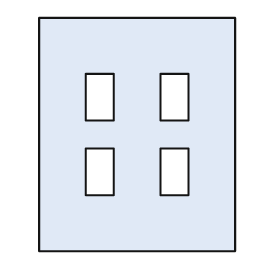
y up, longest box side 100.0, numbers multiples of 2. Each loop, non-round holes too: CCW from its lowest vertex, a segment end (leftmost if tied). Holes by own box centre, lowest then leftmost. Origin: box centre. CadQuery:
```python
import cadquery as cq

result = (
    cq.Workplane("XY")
    .moveTo(-42.0, -50.0)
    .lineTo(42.0, -50.0)
    .lineTo(42.0, 50.0)
    .lineTo(-42.0, 50.0)
    .close()
    .moveTo(-22.0, -26.0)
    .lineTo(-10.0, -26.0)
    .lineTo(-10.0, -6.0)
    .lineTo(-22.0, -6.0)
    .close()
    .moveTo(10.0, -26.0)
    .lineTo(22.0, -26.0)
    .lineTo(22.0, -6.0)
    .lineTo(10.0, -6.0)
    .close()
    .moveTo(-22.0, 6.0)
    .lineTo(-10.0, 6.0)
    .lineTo(-10.0, 26.0)
    .lineTo(-22.0, 26.0)
    .close()
    .moveTo(10.0, 6.0)
    .lineTo(22.0, 6.0)
    .lineTo(22.0, 26.0)
    .lineTo(10.0, 26.0)
    .close()
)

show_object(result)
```